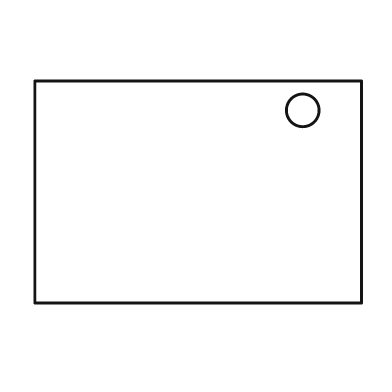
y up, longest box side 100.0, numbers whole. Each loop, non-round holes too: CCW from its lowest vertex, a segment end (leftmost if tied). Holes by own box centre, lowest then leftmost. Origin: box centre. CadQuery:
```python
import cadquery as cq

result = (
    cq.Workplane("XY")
    .moveTo(-50.0, -34.0)
    .lineTo(50.0, -34.0)
    .lineTo(50.0, 34.0)
    .lineTo(-50.0, 34.0)
    .close()
    .moveTo(32.0, 25.0)
    .circle(5.0)
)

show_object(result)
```